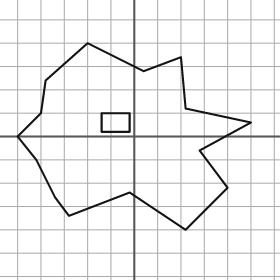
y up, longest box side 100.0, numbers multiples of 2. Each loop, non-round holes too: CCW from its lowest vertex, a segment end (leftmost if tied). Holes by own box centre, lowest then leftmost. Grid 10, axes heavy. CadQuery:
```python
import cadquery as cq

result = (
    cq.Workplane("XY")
    .moveTo(22.0, -40.0)
    .lineTo(40.0, -22.0)
    .lineTo(28.0, -6.0)
    .lineTo(50.0, 6.0)
    .lineTo(22.0, 12.0)
    .lineTo(20.0, 34.0)
    .lineTo(4.0, 28.0)
    .lineTo(-20.0, 40.0)
    .lineTo(-38.0, 24.0)
    .lineTo(-40.0, 10.0)
    .lineTo(-50.0, 0.0)
    .lineTo(-42.0, -10.0)
    .lineTo(-34.0, -26.0)
    .lineTo(-28.0, -34.0)
    .lineTo(-2.0, -24.0)
    .close()
    .moveTo(-14.0, 2.0)
    .lineTo(-2.0, 2.0)
    .lineTo(-2.0, 10.0)
    .lineTo(-14.0, 10.0)
    .close()
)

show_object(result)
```